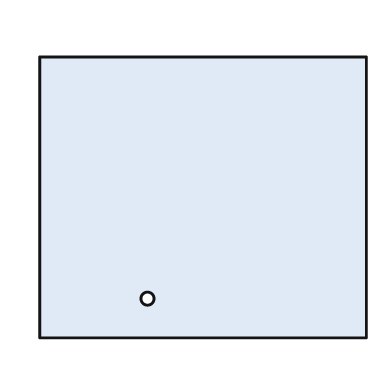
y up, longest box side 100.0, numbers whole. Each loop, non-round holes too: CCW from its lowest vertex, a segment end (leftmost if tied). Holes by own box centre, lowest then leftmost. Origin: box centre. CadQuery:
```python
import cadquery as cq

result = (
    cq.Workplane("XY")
    .moveTo(-50.0, -43.0)
    .lineTo(50.0, -43.0)
    .lineTo(50.0, 43.0)
    .lineTo(-50.0, 43.0)
    .close()
    .moveTo(-17.0, -31.0)
    .circle(2.0)
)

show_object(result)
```